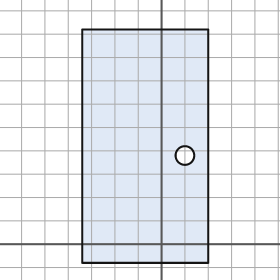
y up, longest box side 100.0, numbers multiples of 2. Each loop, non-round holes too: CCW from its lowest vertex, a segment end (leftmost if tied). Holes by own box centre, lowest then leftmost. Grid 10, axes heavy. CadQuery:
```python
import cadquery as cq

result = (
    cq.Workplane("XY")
    .moveTo(-34.0, -8.0)
    .lineTo(20.0, -8.0)
    .lineTo(20.0, 92.0)
    .lineTo(-34.0, 92.0)
    .close()
    .moveTo(10.0, 38.0)
    .circle(4.0)
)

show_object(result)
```